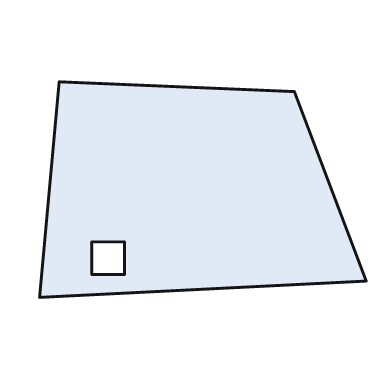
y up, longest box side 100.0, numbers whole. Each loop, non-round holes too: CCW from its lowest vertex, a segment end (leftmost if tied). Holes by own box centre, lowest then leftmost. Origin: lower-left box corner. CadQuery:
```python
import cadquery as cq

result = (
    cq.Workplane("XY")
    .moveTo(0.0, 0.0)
    .lineTo(100.0, 5.0)
    .lineTo(78.0, 63.0)
    .lineTo(6.0, 66.0)
    .close()
    .moveTo(16.0, 7.0)
    .lineTo(26.0, 7.0)
    .lineTo(26.0, 17.0)
    .lineTo(16.0, 17.0)
    .close()
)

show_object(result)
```